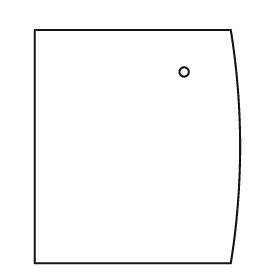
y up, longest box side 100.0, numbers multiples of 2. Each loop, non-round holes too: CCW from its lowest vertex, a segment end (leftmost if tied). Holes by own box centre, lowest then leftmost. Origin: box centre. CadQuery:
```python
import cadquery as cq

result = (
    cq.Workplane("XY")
    .moveTo(-44.0, -50.0)
    .lineTo(40.0, -50.0)
    .threePointArc((44.0, 0.0), (40.0, 50.0))
    .lineTo(-44.0, 50.0)
    .close()
    .moveTo(20.0, 32.0)
    .circle(2.0)
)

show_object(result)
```